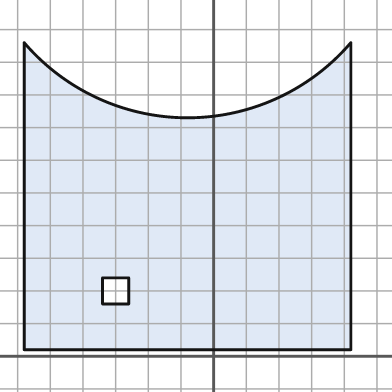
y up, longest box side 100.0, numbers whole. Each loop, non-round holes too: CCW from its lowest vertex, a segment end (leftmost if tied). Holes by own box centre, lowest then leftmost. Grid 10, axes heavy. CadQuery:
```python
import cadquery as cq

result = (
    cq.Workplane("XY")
    .moveTo(-58.0, 2.0)
    .lineTo(42.0, 2.0)
    .lineTo(42.0, 96.0)
    .threePointArc((-8.0, 73.0), (-58.0, 96.0))
    .close()
    .moveTo(-34.0, 16.0)
    .lineTo(-26.0, 16.0)
    .lineTo(-26.0, 24.0)
    .lineTo(-34.0, 24.0)
    .close()
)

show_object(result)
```